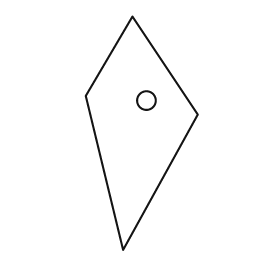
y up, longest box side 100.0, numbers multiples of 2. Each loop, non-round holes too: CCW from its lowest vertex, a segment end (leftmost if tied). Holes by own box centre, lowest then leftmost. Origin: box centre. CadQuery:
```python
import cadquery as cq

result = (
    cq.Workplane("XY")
    .moveTo(-8.0, -50.0)
    .lineTo(24.0, 8.0)
    .lineTo(-4.0, 50.0)
    .lineTo(-24.0, 16.0)
    .close()
    .moveTo(2.0, 14.0)
    .circle(4.0)
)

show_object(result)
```